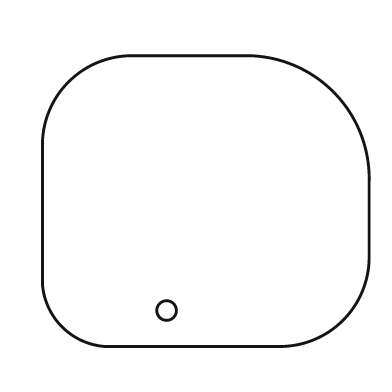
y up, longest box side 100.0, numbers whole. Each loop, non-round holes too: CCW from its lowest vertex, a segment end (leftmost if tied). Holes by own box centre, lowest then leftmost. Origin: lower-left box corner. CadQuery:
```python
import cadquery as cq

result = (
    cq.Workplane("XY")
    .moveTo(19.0, 0.0)
    .lineTo(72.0, 0.0)
    .threePointArc((92.0, 8.0), (100.0, 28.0))
    .lineTo(100.0, 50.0)
    .threePointArc((89.0, 78.0), (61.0, 89.0))
    .lineTo(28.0, 89.0)
    .threePointArc((8.0, 81.0), (0.0, 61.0))
    .lineTo(0.0, 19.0)
    .threePointArc((6.0, 6.0), (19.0, 0.0))
    .close()
    .moveTo(38.0, 11.0)
    .circle(3.0)
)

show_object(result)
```